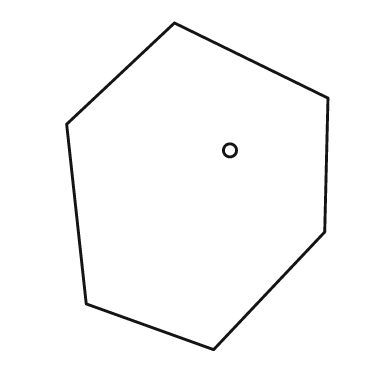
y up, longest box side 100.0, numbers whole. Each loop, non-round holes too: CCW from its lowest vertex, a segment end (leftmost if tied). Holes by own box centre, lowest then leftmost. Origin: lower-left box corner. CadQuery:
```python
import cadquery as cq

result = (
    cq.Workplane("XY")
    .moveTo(45.0, 0.0)
    .lineTo(79.0, 36.0)
    .lineTo(80.0, 77.0)
    .lineTo(33.0, 100.0)
    .lineTo(0.0, 69.0)
    .lineTo(6.0, 14.0)
    .close()
    .moveTo(50.0, 61.0)
    .circle(2.0)
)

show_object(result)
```